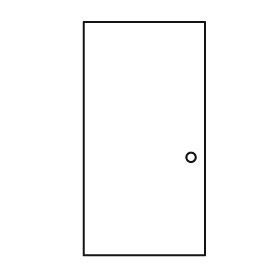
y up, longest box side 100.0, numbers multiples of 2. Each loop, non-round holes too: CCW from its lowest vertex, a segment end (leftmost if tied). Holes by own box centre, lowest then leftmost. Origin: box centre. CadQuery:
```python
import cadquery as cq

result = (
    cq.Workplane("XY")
    .moveTo(-26.0, -50.0)
    .lineTo(26.0, -50.0)
    .lineTo(26.0, 50.0)
    .lineTo(-26.0, 50.0)
    .close()
    .moveTo(20.0, -8.0)
    .circle(2.0)
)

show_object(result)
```